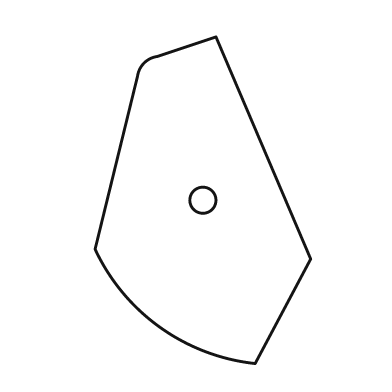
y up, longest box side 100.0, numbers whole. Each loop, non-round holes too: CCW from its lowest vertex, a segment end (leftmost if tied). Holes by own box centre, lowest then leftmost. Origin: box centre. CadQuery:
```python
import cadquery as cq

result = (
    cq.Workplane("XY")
    .moveTo(16.0, -50.0)
    .lineTo(33.0, -18.0)
    .lineTo(4.0, 50.0)
    .lineTo(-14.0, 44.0)
    .threePointArc((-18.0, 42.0), (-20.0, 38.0))
    .lineTo(-33.0, -15.0)
    .threePointArc((-13.0, -39.0), (16.0, -50.0))
    .close()
    .moveTo(0.0, 0.0)
    .circle(4.0)
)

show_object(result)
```